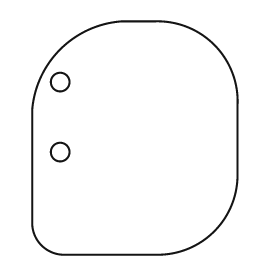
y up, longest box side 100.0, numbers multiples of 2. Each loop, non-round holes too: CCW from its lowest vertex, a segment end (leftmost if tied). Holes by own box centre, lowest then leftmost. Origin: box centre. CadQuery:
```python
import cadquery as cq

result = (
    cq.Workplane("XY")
    .moveTo(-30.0, -50.0)
    .lineTo(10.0, -50.0)
    .threePointArc((34.0, -40.0), (44.0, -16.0))
    .lineTo(44.0, 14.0)
    .threePointArc((34.0, 40.0), (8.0, 50.0))
    .lineTo(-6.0, 50.0)
    .threePointArc((-32.0, 38.0), (-44.0, 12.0))
    .lineTo(-44.0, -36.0)
    .threePointArc((-40.0, -46.0), (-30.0, -50.0))
    .close()
    .moveTo(-32.0, -6.0)
    .circle(4.0)
    .moveTo(-32.0, 24.0)
    .circle(4.0)
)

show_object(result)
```